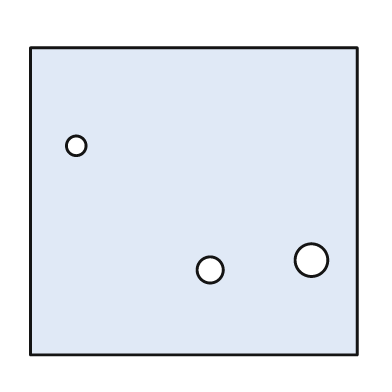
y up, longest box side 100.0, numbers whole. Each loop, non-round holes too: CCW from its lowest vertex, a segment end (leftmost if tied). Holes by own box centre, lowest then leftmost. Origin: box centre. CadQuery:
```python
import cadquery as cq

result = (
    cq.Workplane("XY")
    .moveTo(-50.0, -47.0)
    .lineTo(50.0, -47.0)
    .lineTo(50.0, 47.0)
    .lineTo(-50.0, 47.0)
    .close()
    .moveTo(5.0, -21.0)
    .circle(4.0)
    .moveTo(36.0, -18.0)
    .circle(5.0)
    .moveTo(-36.0, 17.0)
    .circle(3.0)
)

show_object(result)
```